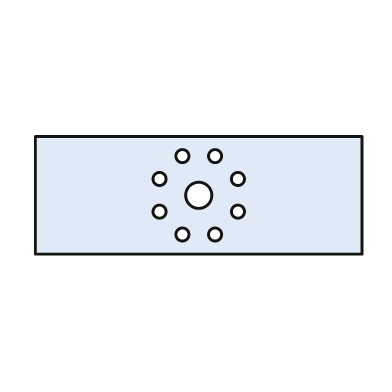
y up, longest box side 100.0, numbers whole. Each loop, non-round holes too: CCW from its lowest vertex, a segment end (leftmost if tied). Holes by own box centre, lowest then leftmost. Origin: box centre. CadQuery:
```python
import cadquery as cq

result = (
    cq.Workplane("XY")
    .moveTo(-50.0, -18.0)
    .lineTo(50.0, -18.0)
    .lineTo(50.0, 18.0)
    .lineTo(-50.0, 18.0)
    .close()
    .moveTo(-5.0, -12.0)
    .circle(2.0)
    .moveTo(5.0, -12.0)
    .circle(2.0)
    .moveTo(-12.0, -5.0)
    .circle(2.0)
    .moveTo(12.0, -5.0)
    .circle(2.0)
    .moveTo(0.0, 0.0)
    .circle(4.0)
    .moveTo(-12.0, 5.0)
    .circle(2.0)
    .moveTo(12.0, 5.0)
    .circle(2.0)
    .moveTo(-5.0, 12.0)
    .circle(2.0)
    .moveTo(5.0, 12.0)
    .circle(2.0)
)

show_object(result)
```